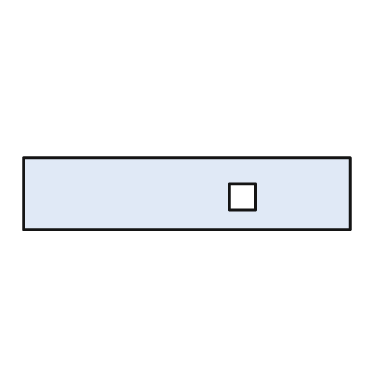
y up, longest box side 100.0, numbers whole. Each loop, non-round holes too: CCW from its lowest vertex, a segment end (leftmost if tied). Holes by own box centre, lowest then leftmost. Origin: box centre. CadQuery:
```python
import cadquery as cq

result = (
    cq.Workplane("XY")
    .moveTo(-50.0, -11.0)
    .lineTo(50.0, -11.0)
    .lineTo(50.0, 11.0)
    .lineTo(-50.0, 11.0)
    .close()
    .moveTo(13.0, -5.0)
    .lineTo(21.0, -5.0)
    .lineTo(21.0, 3.0)
    .lineTo(13.0, 3.0)
    .close()
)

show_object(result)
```